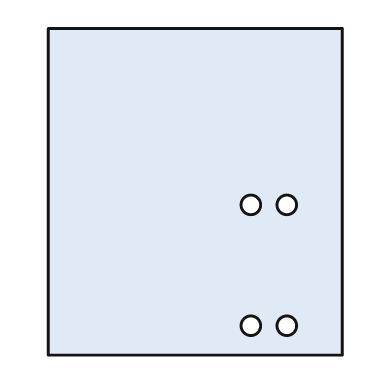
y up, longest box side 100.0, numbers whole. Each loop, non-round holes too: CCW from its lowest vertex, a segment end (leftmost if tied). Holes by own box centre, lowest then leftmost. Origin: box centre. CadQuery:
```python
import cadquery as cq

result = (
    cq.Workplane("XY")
    .moveTo(-45.0, -50.0)
    .lineTo(45.0, -50.0)
    .lineTo(45.0, 50.0)
    .lineTo(-45.0, 50.0)
    .close()
    .moveTo(17.0, -41.0)
    .circle(3.0)
    .moveTo(28.0, -41.0)
    .circle(3.0)
    .moveTo(17.0, -4.0)
    .circle(3.0)
    .moveTo(28.0, -4.0)
    .circle(3.0)
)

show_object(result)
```